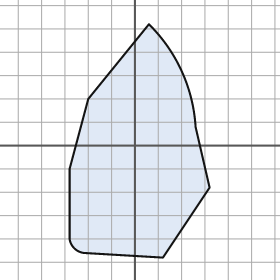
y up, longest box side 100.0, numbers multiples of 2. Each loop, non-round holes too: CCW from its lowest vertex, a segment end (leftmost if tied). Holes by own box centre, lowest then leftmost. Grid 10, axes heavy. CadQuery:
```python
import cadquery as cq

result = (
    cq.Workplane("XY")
    .moveTo(12.0, -48.0)
    .lineTo(32.0, -18.0)
    .lineTo(26.0, 8.0)
    .threePointArc((20.0, 32.0), (6.0, 52.0))
    .lineTo(-20.0, 20.0)
    .lineTo(-28.0, -10.0)
    .lineTo(-28.0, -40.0)
    .threePointArc((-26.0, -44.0), (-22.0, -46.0))
    .close()
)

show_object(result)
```